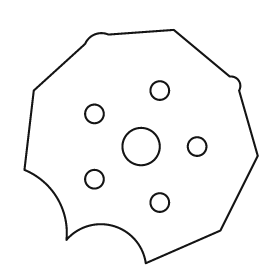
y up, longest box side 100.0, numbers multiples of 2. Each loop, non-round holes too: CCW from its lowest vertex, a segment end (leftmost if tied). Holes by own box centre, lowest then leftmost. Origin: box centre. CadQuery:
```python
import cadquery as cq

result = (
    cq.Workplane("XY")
    .moveTo(2.0, -50.0)
    .lineTo(34.0, -36.0)
    .lineTo(50.0, -4.0)
    .lineTo(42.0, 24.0)
    .threePointArc((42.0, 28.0), (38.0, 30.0))
    .lineTo(14.0, 50.0)
    .lineTo(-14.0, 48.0)
    .threePointArc((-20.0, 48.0), (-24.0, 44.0))
    .lineTo(-46.0, 24.0)
    .lineTo(-50.0, -10.0)
    .threePointArc((-36.0, -22.0), (-32.0, -40.0))
    .threePointArc((-12.0, -34.0), (2.0, -50.0))
    .close()
    .moveTo(8.0, -24.0)
    .circle(4.0)
    .moveTo(-20.0, -14.0)
    .circle(4.0)
    .moveTo(0.0, 0.0)
    .circle(8.0)
    .moveTo(24.0, 0.0)
    .circle(4.0)
    .moveTo(-20.0, 14.0)
    .circle(4.0)
    .moveTo(8.0, 24.0)
    .circle(4.0)
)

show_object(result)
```